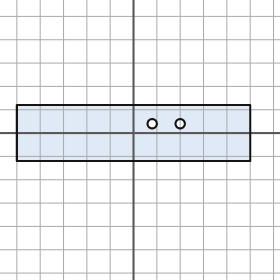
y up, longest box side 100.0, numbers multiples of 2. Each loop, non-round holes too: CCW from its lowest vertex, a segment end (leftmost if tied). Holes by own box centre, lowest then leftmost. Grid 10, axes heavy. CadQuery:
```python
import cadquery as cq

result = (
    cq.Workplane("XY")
    .moveTo(-50.0, -12.0)
    .lineTo(50.0, -12.0)
    .lineTo(50.0, 12.0)
    .lineTo(-50.0, 12.0)
    .close()
    .moveTo(8.0, 4.0)
    .circle(2.0)
    .moveTo(20.0, 4.0)
    .circle(2.0)
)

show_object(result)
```